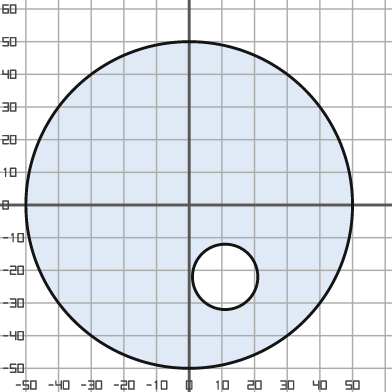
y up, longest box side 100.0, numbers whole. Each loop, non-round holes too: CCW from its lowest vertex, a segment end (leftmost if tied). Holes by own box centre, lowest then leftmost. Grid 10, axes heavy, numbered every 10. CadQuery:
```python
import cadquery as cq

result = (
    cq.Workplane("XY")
    .moveTo(0.0, 0.0)
    .circle(50.0)
    .moveTo(11.0, -22.0)
    .circle(10.0)
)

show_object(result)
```